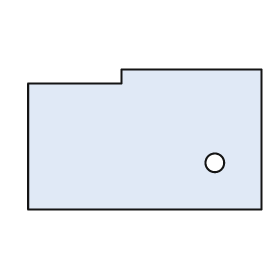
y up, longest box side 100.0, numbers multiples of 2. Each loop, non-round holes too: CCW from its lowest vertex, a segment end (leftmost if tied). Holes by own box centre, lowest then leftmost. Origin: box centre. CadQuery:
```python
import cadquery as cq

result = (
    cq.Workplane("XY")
    .moveTo(-50.0, -30.0)
    .lineTo(50.0, -30.0)
    .lineTo(50.0, 30.0)
    .lineTo(-10.0, 30.0)
    .lineTo(-10.0, 24.0)
    .lineTo(-50.0, 24.0)
    .close()
    .moveTo(30.0, -10.0)
    .circle(4.0)
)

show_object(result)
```